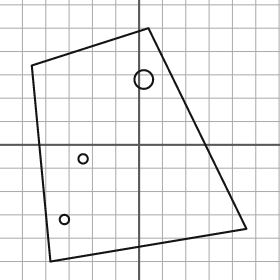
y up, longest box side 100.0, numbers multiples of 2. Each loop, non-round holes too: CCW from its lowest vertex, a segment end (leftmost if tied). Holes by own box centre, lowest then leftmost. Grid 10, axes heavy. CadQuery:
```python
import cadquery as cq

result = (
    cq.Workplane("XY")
    .moveTo(-38.0, -50.0)
    .lineTo(46.0, -36.0)
    .lineTo(4.0, 50.0)
    .lineTo(-46.0, 34.0)
    .close()
    .moveTo(-32.0, -32.0)
    .circle(2.0)
    .moveTo(-24.0, -6.0)
    .circle(2.0)
    .moveTo(2.0, 28.0)
    .circle(4.0)
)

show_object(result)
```